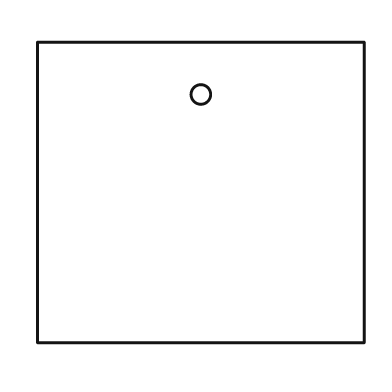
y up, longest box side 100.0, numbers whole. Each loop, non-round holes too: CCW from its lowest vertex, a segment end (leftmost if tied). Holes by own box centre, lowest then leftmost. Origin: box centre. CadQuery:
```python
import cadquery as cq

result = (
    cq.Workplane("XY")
    .moveTo(-50.0, -46.0)
    .lineTo(50.0, -46.0)
    .lineTo(50.0, 46.0)
    .lineTo(-50.0, 46.0)
    .close()
    .moveTo(0.0, 30.0)
    .circle(3.0)
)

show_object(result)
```